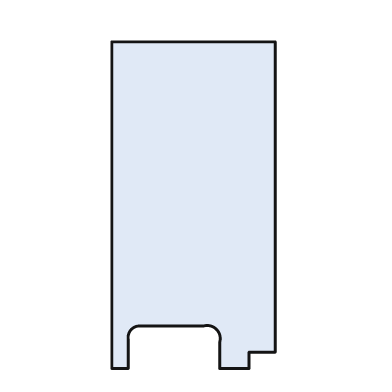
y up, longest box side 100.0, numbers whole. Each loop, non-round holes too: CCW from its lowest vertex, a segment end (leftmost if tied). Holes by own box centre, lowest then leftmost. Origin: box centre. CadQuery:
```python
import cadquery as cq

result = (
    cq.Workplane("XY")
    .moveTo(-25.0, -50.0)
    .lineTo(-20.0, -50.0)
    .lineTo(-20.0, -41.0)
    .threePointArc((-19.0, -38.0), (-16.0, -37.0))
    .lineTo(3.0, -37.0)
    .threePointArc((7.0, -38.0), (8.0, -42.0))
    .lineTo(8.0, -50.0)
    .lineTo(17.0, -50.0)
    .lineTo(17.0, -45.0)
    .lineTo(25.0, -45.0)
    .lineTo(25.0, 50.0)
    .lineTo(-25.0, 50.0)
    .close()
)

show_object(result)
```